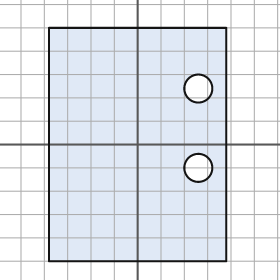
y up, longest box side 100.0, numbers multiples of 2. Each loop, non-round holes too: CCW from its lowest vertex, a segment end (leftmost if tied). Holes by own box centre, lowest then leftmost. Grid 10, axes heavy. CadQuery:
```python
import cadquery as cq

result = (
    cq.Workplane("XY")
    .moveTo(-38.0, -50.0)
    .lineTo(38.0, -50.0)
    .lineTo(38.0, 50.0)
    .lineTo(-38.0, 50.0)
    .close()
    .moveTo(26.0, -10.0)
    .circle(6.0)
    .moveTo(26.0, 24.0)
    .circle(6.0)
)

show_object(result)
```